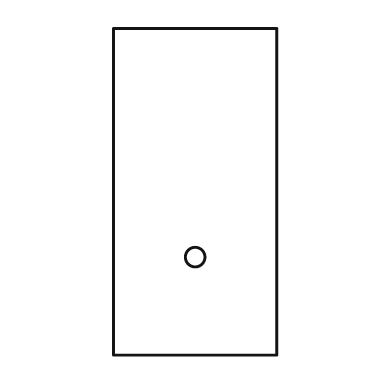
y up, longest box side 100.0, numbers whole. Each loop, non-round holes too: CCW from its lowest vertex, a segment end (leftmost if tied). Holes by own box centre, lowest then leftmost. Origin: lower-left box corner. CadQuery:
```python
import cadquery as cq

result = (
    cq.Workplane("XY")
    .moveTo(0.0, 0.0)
    .lineTo(50.0, 0.0)
    .lineTo(50.0, 100.0)
    .lineTo(0.0, 100.0)
    .close()
    .moveTo(25.0, 30.0)
    .circle(3.0)
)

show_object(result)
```